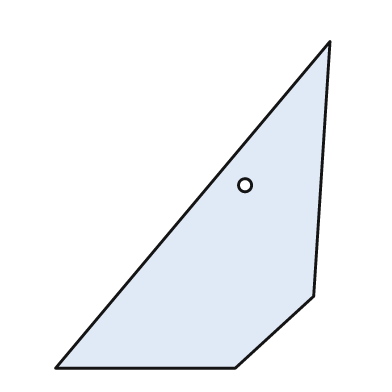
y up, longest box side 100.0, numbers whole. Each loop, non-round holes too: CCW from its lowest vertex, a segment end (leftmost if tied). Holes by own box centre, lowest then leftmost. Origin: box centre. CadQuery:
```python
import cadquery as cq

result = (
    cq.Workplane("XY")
    .moveTo(-42.0, -50.0)
    .lineTo(13.0, -50.0)
    .lineTo(37.0, -28.0)
    .lineTo(42.0, 50.0)
    .close()
    .moveTo(16.0, 6.0)
    .circle(2.0)
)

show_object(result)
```